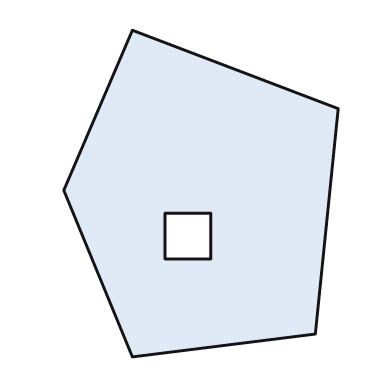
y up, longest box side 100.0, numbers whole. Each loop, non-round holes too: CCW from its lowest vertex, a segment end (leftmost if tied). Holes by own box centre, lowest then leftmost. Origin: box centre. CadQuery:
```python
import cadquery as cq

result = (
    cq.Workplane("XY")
    .moveTo(-21.0, -50.0)
    .lineTo(35.0, -43.0)
    .lineTo(42.0, 26.0)
    .lineTo(-21.0, 50.0)
    .lineTo(-42.0, 1.0)
    .close()
    .moveTo(-11.0, -20.0)
    .lineTo(3.0, -20.0)
    .lineTo(3.0, -6.0)
    .lineTo(-11.0, -6.0)
    .close()
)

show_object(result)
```